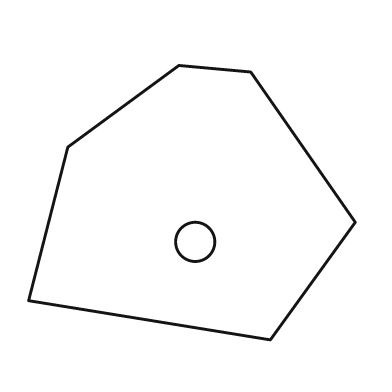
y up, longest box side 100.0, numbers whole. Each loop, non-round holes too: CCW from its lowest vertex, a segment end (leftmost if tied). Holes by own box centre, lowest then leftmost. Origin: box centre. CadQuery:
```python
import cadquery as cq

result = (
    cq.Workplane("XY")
    .moveTo(24.0, -42.0)
    .lineTo(50.0, -6.0)
    .lineTo(18.0, 40.0)
    .lineTo(-4.0, 42.0)
    .lineTo(-38.0, 17.0)
    .lineTo(-50.0, -30.0)
    .close()
    .moveTo(1.0, -12.0)
    .circle(6.0)
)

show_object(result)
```